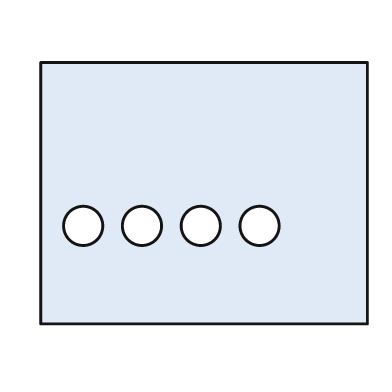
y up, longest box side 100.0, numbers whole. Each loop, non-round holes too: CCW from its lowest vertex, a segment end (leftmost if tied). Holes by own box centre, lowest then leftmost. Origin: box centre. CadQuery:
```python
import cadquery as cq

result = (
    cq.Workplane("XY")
    .moveTo(-50.0, -40.0)
    .lineTo(50.0, -40.0)
    .lineTo(50.0, 40.0)
    .lineTo(-50.0, 40.0)
    .close()
    .moveTo(-37.0, -10.0)
    .circle(6.0)
    .moveTo(-19.0, -10.0)
    .circle(6.0)
    .moveTo(-1.0, -10.0)
    .circle(6.0)
    .moveTo(17.0, -10.0)
    .circle(6.0)
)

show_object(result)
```